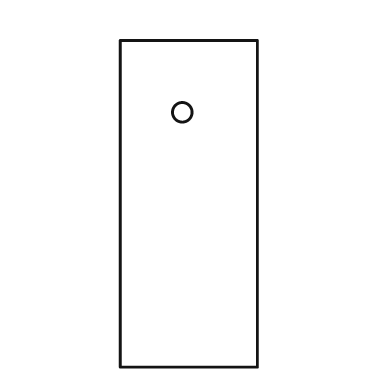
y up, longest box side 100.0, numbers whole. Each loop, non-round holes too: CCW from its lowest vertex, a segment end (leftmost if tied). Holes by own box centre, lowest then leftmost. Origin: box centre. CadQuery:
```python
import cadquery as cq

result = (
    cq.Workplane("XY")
    .moveTo(-21.0, -50.0)
    .lineTo(21.0, -50.0)
    .lineTo(21.0, 50.0)
    .lineTo(-21.0, 50.0)
    .close()
    .moveTo(-2.0, 28.0)
    .circle(3.0)
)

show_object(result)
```